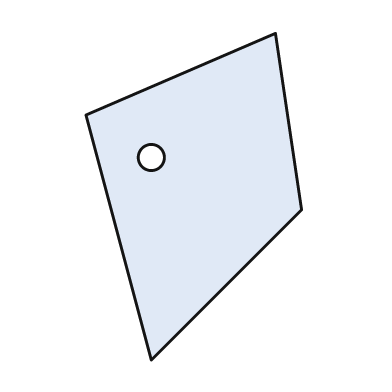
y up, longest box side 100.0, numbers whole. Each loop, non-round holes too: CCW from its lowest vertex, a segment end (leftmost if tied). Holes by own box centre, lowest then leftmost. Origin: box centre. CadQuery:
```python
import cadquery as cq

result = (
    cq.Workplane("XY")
    .moveTo(-13.0, -50.0)
    .lineTo(33.0, -4.0)
    .lineTo(25.0, 50.0)
    .lineTo(-33.0, 25.0)
    .close()
    .moveTo(-13.0, 12.0)
    .circle(4.0)
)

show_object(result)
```